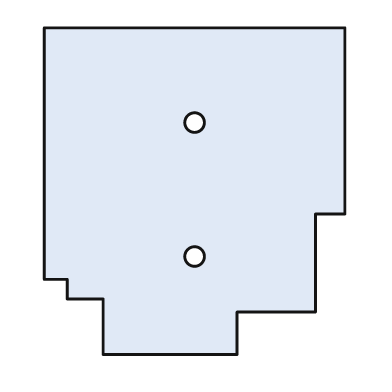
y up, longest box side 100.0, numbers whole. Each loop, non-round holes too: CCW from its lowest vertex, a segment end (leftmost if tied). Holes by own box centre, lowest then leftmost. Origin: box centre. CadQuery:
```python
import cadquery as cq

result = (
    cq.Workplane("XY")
    .moveTo(-28.0, -50.0)
    .lineTo(13.0, -50.0)
    .lineTo(13.0, -37.0)
    .lineTo(37.0, -37.0)
    .lineTo(37.0, -7.0)
    .lineTo(46.0, -7.0)
    .lineTo(46.0, 50.0)
    .lineTo(-46.0, 50.0)
    .lineTo(-46.0, -27.0)
    .lineTo(-39.0, -27.0)
    .lineTo(-39.0, -33.0)
    .lineTo(-28.0, -33.0)
    .close()
    .moveTo(0.0, -20.0)
    .circle(3.0)
    .moveTo(0.0, 21.0)
    .circle(3.0)
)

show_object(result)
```